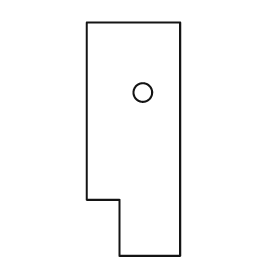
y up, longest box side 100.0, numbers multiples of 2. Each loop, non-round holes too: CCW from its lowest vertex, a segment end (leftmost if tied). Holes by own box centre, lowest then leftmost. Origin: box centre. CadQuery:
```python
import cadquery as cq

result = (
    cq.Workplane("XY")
    .moveTo(-6.0, -50.0)
    .lineTo(20.0, -50.0)
    .lineTo(20.0, 50.0)
    .lineTo(-20.0, 50.0)
    .lineTo(-20.0, -26.0)
    .lineTo(-6.0, -26.0)
    .close()
    .moveTo(4.0, 20.0)
    .circle(4.0)
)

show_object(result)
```